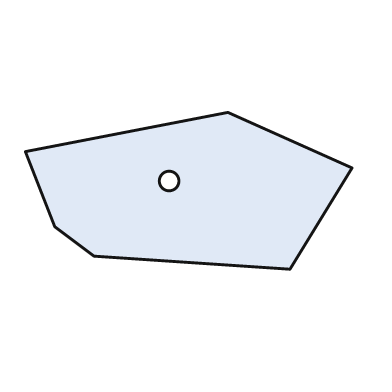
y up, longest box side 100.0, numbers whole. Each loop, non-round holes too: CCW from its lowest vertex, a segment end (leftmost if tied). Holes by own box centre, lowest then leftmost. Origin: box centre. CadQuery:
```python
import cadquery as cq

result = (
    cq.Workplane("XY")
    .moveTo(31.0, -24.0)
    .lineTo(50.0, 7.0)
    .lineTo(12.0, 24.0)
    .lineTo(-50.0, 12.0)
    .lineTo(-41.0, -11.0)
    .lineTo(-29.0, -20.0)
    .close()
    .moveTo(-6.0, 3.0)
    .circle(3.0)
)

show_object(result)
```